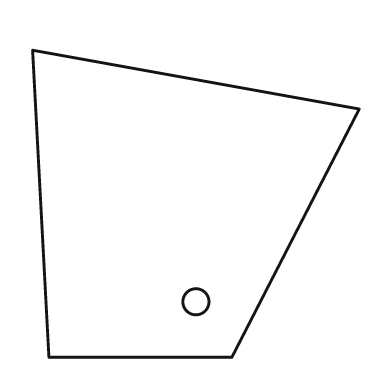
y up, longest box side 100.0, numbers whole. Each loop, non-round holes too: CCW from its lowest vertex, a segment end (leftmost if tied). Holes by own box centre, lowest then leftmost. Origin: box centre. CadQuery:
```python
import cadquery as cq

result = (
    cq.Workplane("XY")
    .moveTo(-45.0, -47.0)
    .lineTo(11.0, -47.0)
    .lineTo(50.0, 29.0)
    .lineTo(-50.0, 47.0)
    .close()
    .moveTo(0.0, -30.0)
    .circle(4.0)
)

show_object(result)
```